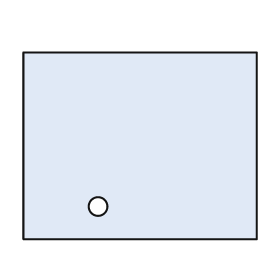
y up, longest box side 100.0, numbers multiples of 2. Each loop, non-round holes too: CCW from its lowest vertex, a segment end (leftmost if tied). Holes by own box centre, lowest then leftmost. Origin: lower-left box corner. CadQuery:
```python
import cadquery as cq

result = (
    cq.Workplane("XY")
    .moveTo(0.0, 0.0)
    .lineTo(100.0, 0.0)
    .lineTo(100.0, 80.0)
    .lineTo(0.0, 80.0)
    .close()
    .moveTo(32.0, 14.0)
    .circle(4.0)
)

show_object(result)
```